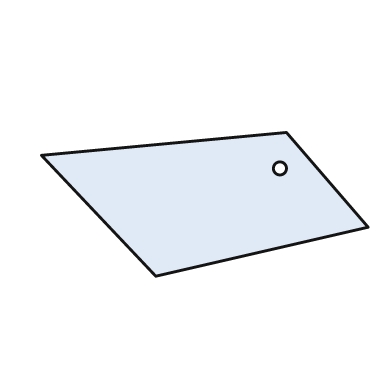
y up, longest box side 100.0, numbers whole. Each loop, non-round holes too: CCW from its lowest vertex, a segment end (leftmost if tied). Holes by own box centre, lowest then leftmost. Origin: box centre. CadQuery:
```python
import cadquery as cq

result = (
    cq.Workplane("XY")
    .moveTo(-15.0, -22.0)
    .lineTo(50.0, -7.0)
    .lineTo(25.0, 22.0)
    .lineTo(-50.0, 15.0)
    .close()
    .moveTo(23.0, 11.0)
    .circle(2.0)
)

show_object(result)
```